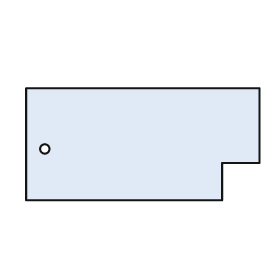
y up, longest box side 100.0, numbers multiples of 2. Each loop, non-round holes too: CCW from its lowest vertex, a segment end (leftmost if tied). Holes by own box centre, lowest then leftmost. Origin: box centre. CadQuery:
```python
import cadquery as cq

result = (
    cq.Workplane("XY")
    .moveTo(-50.0, -24.0)
    .lineTo(34.0, -24.0)
    .lineTo(34.0, -8.0)
    .lineTo(50.0, -8.0)
    .lineTo(50.0, 24.0)
    .lineTo(-50.0, 24.0)
    .close()
    .moveTo(-42.0, -2.0)
    .circle(2.0)
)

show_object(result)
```